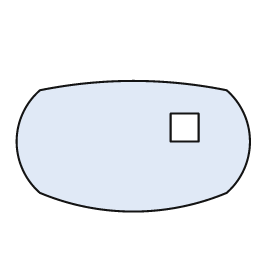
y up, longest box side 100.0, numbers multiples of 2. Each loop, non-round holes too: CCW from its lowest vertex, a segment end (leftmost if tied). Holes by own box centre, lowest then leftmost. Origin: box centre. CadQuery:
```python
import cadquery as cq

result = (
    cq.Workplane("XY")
    .moveTo(-40.0, -20.0)
    .threePointArc((0.0, -28.0), (40.0, -20.0))
    .threePointArc((50.0, 2.0), (40.0, 24.0))
    .threePointArc((0.0, 28.0), (-40.0, 24.0))
    .threePointArc((-50.0, 2.0), (-40.0, -20.0))
    .close()
    .moveTo(16.0, 2.0)
    .lineTo(28.0, 2.0)
    .lineTo(28.0, 14.0)
    .lineTo(16.0, 14.0)
    .close()
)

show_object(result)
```